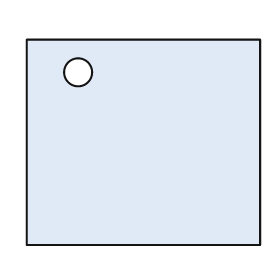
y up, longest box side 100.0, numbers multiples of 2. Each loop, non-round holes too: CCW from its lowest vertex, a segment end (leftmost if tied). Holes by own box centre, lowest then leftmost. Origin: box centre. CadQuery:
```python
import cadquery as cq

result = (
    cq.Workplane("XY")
    .moveTo(-50.0, -44.0)
    .lineTo(50.0, -44.0)
    .lineTo(50.0, 44.0)
    .lineTo(-50.0, 44.0)
    .close()
    .moveTo(-28.0, 30.0)
    .circle(6.0)
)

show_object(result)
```